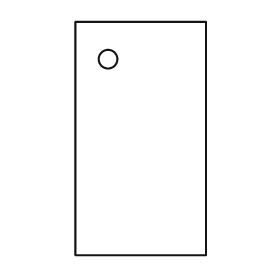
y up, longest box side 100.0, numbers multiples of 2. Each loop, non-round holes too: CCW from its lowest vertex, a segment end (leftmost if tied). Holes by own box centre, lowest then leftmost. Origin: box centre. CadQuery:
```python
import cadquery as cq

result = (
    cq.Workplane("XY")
    .moveTo(-28.0, -50.0)
    .lineTo(28.0, -50.0)
    .lineTo(28.0, 50.0)
    .lineTo(-28.0, 50.0)
    .close()
    .moveTo(-14.0, 34.0)
    .circle(4.0)
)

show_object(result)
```